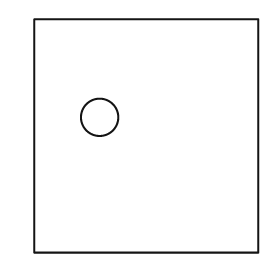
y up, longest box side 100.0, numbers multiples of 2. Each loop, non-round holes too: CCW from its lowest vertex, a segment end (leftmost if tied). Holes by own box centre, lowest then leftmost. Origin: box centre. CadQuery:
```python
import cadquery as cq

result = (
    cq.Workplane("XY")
    .moveTo(-48.0, -50.0)
    .lineTo(48.0, -50.0)
    .lineTo(48.0, 50.0)
    .lineTo(-48.0, 50.0)
    .close()
    .moveTo(-20.0, 8.0)
    .circle(8.0)
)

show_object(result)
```